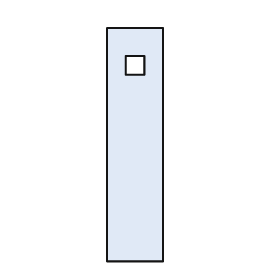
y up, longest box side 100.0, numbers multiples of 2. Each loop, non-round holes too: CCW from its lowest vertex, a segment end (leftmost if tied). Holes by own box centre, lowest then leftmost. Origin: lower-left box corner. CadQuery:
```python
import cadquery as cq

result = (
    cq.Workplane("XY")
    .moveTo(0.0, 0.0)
    .lineTo(24.0, 0.0)
    .lineTo(24.0, 100.0)
    .lineTo(0.0, 100.0)
    .close()
    .moveTo(8.0, 80.0)
    .lineTo(16.0, 80.0)
    .lineTo(16.0, 88.0)
    .lineTo(8.0, 88.0)
    .close()
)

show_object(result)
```